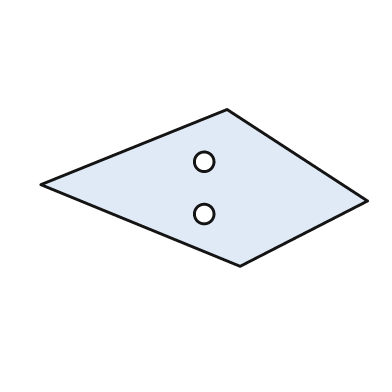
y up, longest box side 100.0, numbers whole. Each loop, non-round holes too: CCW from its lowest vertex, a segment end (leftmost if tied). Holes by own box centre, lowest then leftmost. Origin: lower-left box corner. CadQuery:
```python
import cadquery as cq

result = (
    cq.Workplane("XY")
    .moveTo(61.0, 0.0)
    .lineTo(100.0, 20.0)
    .lineTo(57.0, 48.0)
    .lineTo(0.0, 25.0)
    .close()
    .moveTo(50.0, 16.0)
    .circle(3.0)
    .moveTo(50.0, 32.0)
    .circle(3.0)
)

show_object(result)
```